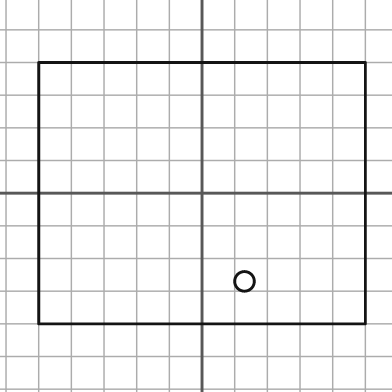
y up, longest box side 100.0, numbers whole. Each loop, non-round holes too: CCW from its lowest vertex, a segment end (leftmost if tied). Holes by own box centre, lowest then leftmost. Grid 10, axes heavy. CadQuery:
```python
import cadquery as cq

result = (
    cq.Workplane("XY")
    .moveTo(-50.0, -40.0)
    .lineTo(50.0, -40.0)
    .lineTo(50.0, 40.0)
    .lineTo(-50.0, 40.0)
    .close()
    .moveTo(13.0, -27.0)
    .circle(3.0)
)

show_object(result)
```